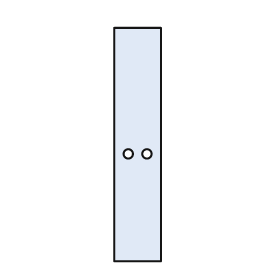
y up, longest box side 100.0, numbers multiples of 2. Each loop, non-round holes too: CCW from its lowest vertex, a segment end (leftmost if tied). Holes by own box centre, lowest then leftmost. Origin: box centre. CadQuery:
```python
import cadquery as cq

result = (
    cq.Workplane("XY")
    .moveTo(-10.0, -50.0)
    .lineTo(10.0, -50.0)
    .lineTo(10.0, 50.0)
    .lineTo(-10.0, 50.0)
    .close()
    .moveTo(-4.0, -4.0)
    .circle(2.0)
    .moveTo(4.0, -4.0)
    .circle(2.0)
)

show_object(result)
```